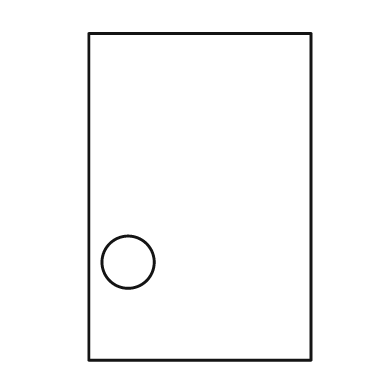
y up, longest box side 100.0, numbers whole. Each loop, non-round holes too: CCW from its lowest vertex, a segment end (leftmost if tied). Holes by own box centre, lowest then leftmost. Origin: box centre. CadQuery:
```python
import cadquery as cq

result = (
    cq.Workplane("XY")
    .moveTo(-34.0, -50.0)
    .lineTo(34.0, -50.0)
    .lineTo(34.0, 50.0)
    .lineTo(-34.0, 50.0)
    .close()
    .moveTo(-22.0, -20.0)
    .circle(8.0)
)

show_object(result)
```